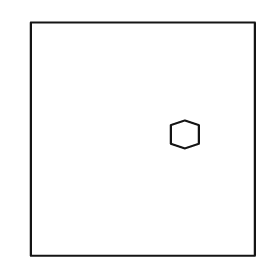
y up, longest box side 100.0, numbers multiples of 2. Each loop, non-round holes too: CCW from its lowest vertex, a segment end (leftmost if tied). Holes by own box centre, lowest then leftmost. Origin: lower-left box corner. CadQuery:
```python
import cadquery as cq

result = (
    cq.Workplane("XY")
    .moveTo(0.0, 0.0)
    .lineTo(96.0, 0.0)
    .lineTo(96.0, 100.0)
    .lineTo(0.0, 100.0)
    .close()
    .moveTo(66.0, 46.0)
    .lineTo(72.0, 48.0)
    .lineTo(72.0, 56.0)
    .lineTo(66.0, 58.0)
    .lineTo(60.0, 56.0)
    .lineTo(60.0, 48.0)
    .close()
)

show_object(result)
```